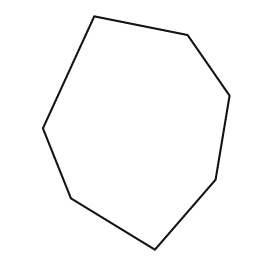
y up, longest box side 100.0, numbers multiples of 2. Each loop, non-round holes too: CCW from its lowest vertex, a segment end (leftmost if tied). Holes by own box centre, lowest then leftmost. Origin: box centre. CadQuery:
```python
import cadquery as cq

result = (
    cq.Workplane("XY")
    .moveTo(8.0, -50.0)
    .lineTo(34.0, -20.0)
    .lineTo(40.0, 16.0)
    .lineTo(22.0, 42.0)
    .lineTo(-18.0, 50.0)
    .lineTo(-40.0, 2.0)
    .lineTo(-28.0, -28.0)
    .close()
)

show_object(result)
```